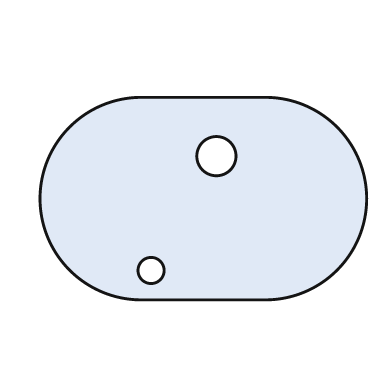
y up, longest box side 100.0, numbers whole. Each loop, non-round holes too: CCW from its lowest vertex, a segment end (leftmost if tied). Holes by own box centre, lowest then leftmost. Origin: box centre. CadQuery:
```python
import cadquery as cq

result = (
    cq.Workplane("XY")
    .moveTo(-19.0, -31.0)
    .lineTo(19.0, -31.0)
    .threePointArc((50.0, 0.0), (19.0, 31.0))
    .lineTo(-19.0, 31.0)
    .threePointArc((-50.0, 0.0), (-19.0, -31.0))
    .close()
    .moveTo(-16.0, -22.0)
    .circle(4.0)
    .moveTo(4.0, 13.0)
    .circle(6.0)
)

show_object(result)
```